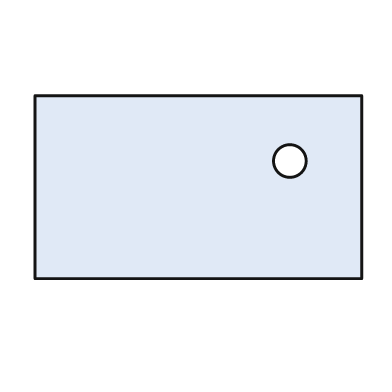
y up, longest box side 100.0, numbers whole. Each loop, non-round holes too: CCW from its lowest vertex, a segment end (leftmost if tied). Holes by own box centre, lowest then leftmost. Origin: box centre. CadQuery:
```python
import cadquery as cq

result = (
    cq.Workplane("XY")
    .moveTo(-50.0, -28.0)
    .lineTo(50.0, -28.0)
    .lineTo(50.0, 28.0)
    .lineTo(-50.0, 28.0)
    .close()
    .moveTo(28.0, 8.0)
    .circle(5.0)
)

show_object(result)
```